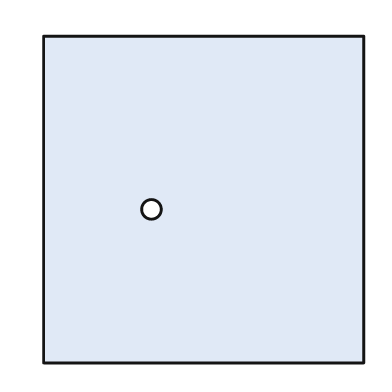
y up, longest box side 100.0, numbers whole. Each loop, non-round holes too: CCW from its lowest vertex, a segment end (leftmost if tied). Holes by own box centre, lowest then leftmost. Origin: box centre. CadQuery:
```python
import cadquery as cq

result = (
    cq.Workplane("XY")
    .moveTo(-49.0, -50.0)
    .lineTo(49.0, -50.0)
    .lineTo(49.0, 50.0)
    .lineTo(-49.0, 50.0)
    .close()
    .moveTo(-16.0, -3.0)
    .circle(3.0)
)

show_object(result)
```